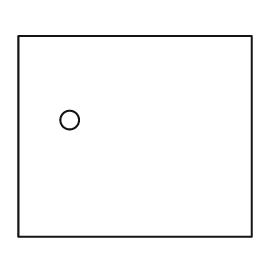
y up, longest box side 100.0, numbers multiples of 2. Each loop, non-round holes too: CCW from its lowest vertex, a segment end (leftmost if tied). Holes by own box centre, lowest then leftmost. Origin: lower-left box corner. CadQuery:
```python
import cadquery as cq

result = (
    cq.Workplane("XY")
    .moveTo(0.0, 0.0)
    .lineTo(100.0, 0.0)
    .lineTo(100.0, 86.0)
    .lineTo(0.0, 86.0)
    .close()
    .moveTo(22.0, 50.0)
    .circle(4.0)
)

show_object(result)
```